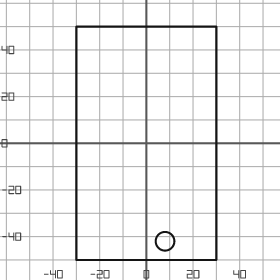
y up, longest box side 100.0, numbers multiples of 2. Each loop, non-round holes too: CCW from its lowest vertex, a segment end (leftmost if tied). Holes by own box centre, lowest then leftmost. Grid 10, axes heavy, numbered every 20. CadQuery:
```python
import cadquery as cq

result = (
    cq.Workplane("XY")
    .moveTo(-30.0, -50.0)
    .lineTo(30.0, -50.0)
    .lineTo(30.0, 50.0)
    .lineTo(-30.0, 50.0)
    .close()
    .moveTo(8.0, -42.0)
    .circle(4.0)
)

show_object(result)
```